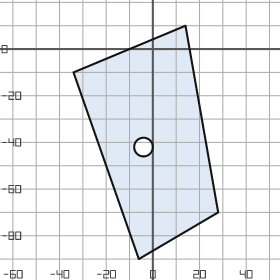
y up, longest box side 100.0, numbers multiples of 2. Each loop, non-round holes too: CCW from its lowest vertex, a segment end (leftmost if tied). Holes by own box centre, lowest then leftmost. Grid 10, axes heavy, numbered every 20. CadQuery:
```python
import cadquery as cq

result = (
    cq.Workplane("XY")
    .moveTo(-6.0, -90.0)
    .lineTo(28.0, -70.0)
    .lineTo(14.0, 10.0)
    .lineTo(-34.0, -10.0)
    .close()
    .moveTo(-4.0, -42.0)
    .circle(4.0)
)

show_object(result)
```